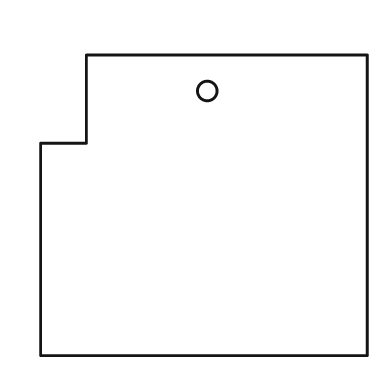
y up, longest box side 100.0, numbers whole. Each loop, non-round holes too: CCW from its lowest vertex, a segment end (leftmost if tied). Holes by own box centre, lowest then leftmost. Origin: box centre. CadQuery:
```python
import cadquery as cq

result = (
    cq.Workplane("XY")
    .moveTo(-50.0, -46.0)
    .lineTo(50.0, -46.0)
    .lineTo(50.0, 46.0)
    .lineTo(-36.0, 46.0)
    .lineTo(-36.0, 19.0)
    .lineTo(-50.0, 19.0)
    .close()
    .moveTo(1.0, 35.0)
    .circle(3.0)
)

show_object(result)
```